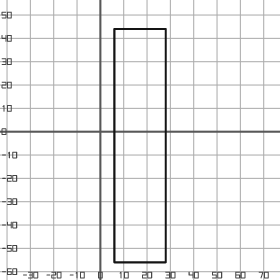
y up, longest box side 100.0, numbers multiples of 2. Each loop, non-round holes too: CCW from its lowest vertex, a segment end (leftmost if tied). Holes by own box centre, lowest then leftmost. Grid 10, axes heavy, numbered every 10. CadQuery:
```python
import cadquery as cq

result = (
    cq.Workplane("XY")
    .moveTo(6.0, -56.0)
    .lineTo(28.0, -56.0)
    .lineTo(28.0, 44.0)
    .lineTo(6.0, 44.0)
    .close()
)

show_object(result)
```